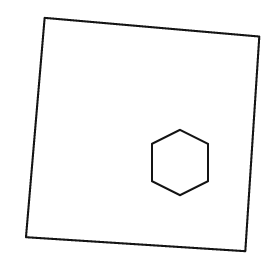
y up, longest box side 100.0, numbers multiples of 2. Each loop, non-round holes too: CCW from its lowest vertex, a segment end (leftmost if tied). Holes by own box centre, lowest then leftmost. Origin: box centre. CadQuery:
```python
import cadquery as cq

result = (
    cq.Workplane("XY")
    .moveTo(44.0, -50.0)
    .lineTo(50.0, 42.0)
    .lineTo(-42.0, 50.0)
    .lineTo(-50.0, -44.0)
    .close()
    .moveTo(16.0, -26.0)
    .lineTo(28.0, -20.0)
    .lineTo(28.0, -4.0)
    .lineTo(16.0, 2.0)
    .lineTo(4.0, -4.0)
    .lineTo(4.0, -20.0)
    .close()
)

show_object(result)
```